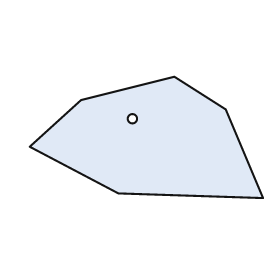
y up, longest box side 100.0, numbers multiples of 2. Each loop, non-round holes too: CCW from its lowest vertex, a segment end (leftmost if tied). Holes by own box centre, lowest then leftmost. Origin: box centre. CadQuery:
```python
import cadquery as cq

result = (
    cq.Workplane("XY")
    .moveTo(50.0, -26.0)
    .lineTo(34.0, 12.0)
    .lineTo(12.0, 26.0)
    .lineTo(-28.0, 16.0)
    .lineTo(-50.0, -4.0)
    .lineTo(-12.0, -24.0)
    .close()
    .moveTo(-6.0, 8.0)
    .circle(2.0)
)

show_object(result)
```